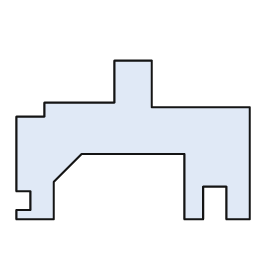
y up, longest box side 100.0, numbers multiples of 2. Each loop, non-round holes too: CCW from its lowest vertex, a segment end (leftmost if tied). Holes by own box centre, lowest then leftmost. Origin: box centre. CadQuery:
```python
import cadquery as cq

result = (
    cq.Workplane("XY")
    .moveTo(-50.0, -34.0)
    .lineTo(-34.0, -34.0)
    .lineTo(-34.0, -18.0)
    .lineTo(-22.0, -6.0)
    .lineTo(22.0, -6.0)
    .lineTo(22.0, -34.0)
    .lineTo(30.0, -34.0)
    .lineTo(30.0, -20.0)
    .lineTo(40.0, -20.0)
    .lineTo(40.0, -34.0)
    .lineTo(50.0, -34.0)
    .lineTo(50.0, 14.0)
    .lineTo(8.0, 14.0)
    .lineTo(8.0, 34.0)
    .lineTo(-8.0, 34.0)
    .lineTo(-8.0, 16.0)
    .lineTo(-38.0, 16.0)
    .lineTo(-38.0, 10.0)
    .lineTo(-50.0, 10.0)
    .lineTo(-50.0, -22.0)
    .lineTo(-44.0, -22.0)
    .lineTo(-44.0, -30.0)
    .lineTo(-50.0, -30.0)
    .close()
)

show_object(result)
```